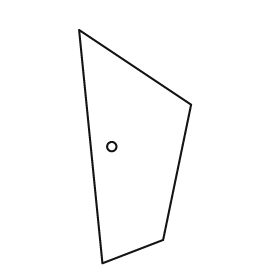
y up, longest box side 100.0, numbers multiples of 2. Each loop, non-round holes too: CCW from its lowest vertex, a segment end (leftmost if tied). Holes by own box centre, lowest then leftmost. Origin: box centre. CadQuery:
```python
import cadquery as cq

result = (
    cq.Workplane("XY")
    .moveTo(-14.0, -50.0)
    .lineTo(12.0, -40.0)
    .lineTo(24.0, 18.0)
    .lineTo(-24.0, 50.0)
    .close()
    .moveTo(-10.0, 0.0)
    .circle(2.0)
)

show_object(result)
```